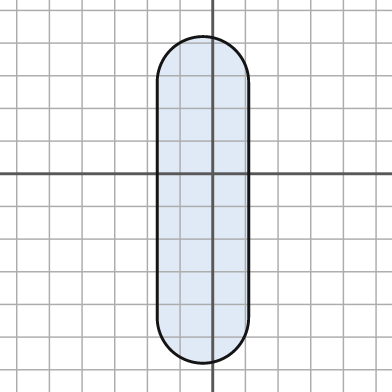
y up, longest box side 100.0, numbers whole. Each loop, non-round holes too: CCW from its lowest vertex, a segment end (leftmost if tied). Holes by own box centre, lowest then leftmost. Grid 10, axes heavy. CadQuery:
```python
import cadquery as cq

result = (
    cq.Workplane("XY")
    .moveTo(-17.0, -44.0)
    .threePointArc((-3.0, -58.0), (11.0, -44.0))
    .lineTo(11.0, 28.0)
    .threePointArc((-3.0, 42.0), (-17.0, 28.0))
    .close()
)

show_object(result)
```